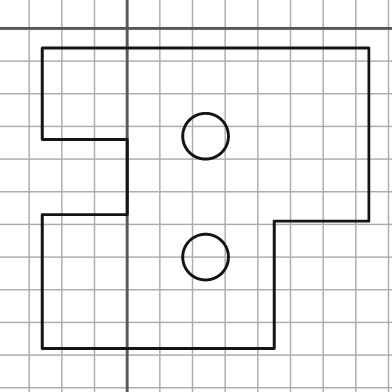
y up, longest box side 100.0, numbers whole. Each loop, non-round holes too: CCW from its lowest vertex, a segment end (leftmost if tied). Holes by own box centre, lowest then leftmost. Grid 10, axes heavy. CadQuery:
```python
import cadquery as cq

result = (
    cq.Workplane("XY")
    .moveTo(-26.0, -98.0)
    .lineTo(45.0, -98.0)
    .lineTo(45.0, -59.0)
    .lineTo(74.0, -59.0)
    .lineTo(74.0, -6.0)
    .lineTo(-26.0, -6.0)
    .lineTo(-26.0, -34.0)
    .lineTo(0.0, -34.0)
    .lineTo(0.0, -57.0)
    .lineTo(-26.0, -57.0)
    .close()
    .moveTo(24.0, -70.0)
    .circle(7.0)
    .moveTo(24.0, -33.0)
    .circle(7.0)
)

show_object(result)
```